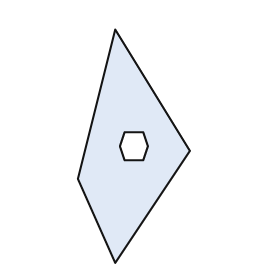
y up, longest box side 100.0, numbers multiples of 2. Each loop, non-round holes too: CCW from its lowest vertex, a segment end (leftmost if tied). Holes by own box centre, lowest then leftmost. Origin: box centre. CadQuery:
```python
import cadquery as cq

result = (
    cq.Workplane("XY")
    .moveTo(-8.0, -50.0)
    .lineTo(24.0, -2.0)
    .lineTo(-8.0, 50.0)
    .lineTo(-24.0, -14.0)
    .close()
    .moveTo(-4.0, -6.0)
    .lineTo(4.0, -6.0)
    .lineTo(6.0, 0.0)
    .lineTo(4.0, 6.0)
    .lineTo(-4.0, 6.0)
    .lineTo(-6.0, 0.0)
    .close()
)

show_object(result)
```